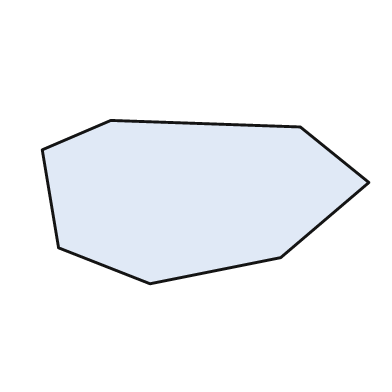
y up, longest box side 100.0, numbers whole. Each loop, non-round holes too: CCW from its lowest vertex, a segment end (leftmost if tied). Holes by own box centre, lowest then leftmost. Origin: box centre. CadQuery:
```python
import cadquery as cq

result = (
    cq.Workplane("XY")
    .moveTo(-17.0, -25.0)
    .lineTo(23.0, -17.0)
    .lineTo(50.0, 6.0)
    .lineTo(29.0, 23.0)
    .lineTo(-29.0, 25.0)
    .lineTo(-50.0, 16.0)
    .lineTo(-45.0, -14.0)
    .close()
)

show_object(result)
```